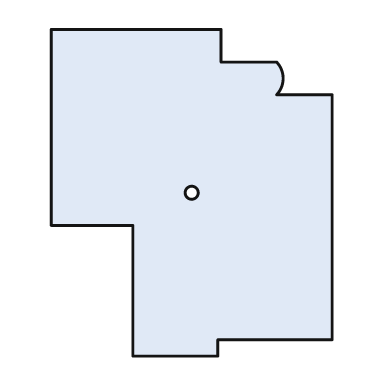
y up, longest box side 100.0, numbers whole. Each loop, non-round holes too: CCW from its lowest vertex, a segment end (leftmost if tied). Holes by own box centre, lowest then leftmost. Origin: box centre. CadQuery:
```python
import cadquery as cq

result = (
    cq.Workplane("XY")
    .moveTo(-18.0, -50.0)
    .lineTo(8.0, -50.0)
    .lineTo(8.0, -45.0)
    .lineTo(43.0, -45.0)
    .lineTo(43.0, 30.0)
    .lineTo(26.0, 30.0)
    .threePointArc((28.0, 35.0), (26.0, 40.0))
    .lineTo(9.0, 40.0)
    .lineTo(9.0, 50.0)
    .lineTo(-43.0, 50.0)
    .lineTo(-43.0, -10.0)
    .lineTo(-18.0, -10.0)
    .close()
    .moveTo(0.0, 0.0)
    .circle(2.0)
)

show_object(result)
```